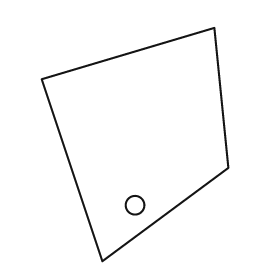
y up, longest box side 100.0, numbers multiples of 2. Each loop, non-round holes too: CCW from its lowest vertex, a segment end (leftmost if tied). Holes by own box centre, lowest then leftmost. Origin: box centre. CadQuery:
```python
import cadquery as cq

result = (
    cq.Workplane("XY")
    .moveTo(-14.0, -50.0)
    .lineTo(40.0, -10.0)
    .lineTo(34.0, 50.0)
    .lineTo(-40.0, 28.0)
    .close()
    .moveTo(0.0, -26.0)
    .circle(4.0)
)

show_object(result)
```